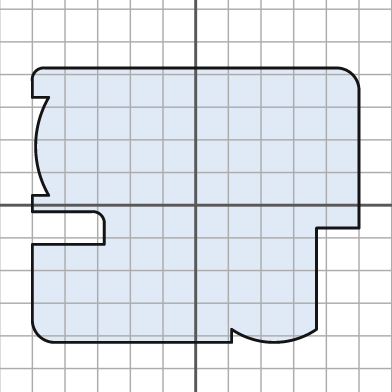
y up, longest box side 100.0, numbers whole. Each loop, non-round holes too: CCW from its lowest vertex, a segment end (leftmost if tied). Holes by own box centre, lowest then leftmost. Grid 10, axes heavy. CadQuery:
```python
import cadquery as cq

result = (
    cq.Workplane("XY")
    .moveTo(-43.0, -42.0)
    .lineTo(11.0, -42.0)
    .lineTo(11.0, -38.0)
    .threePointArc((24.0, -42.0), (37.0, -38.0))
    .lineTo(37.0, -7.0)
    .lineTo(50.0, -7.0)
    .lineTo(50.0, 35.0)
    .threePointArc((48.0, 40.0), (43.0, 42.0))
    .lineTo(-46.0, 42.0)
    .threePointArc((-49.0, 41.0), (-50.0, 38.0))
    .lineTo(-50.0, 33.0)
    .lineTo(-45.0, 33.0)
    .threePointArc((-49.0, 18.0), (-45.0, 3.0))
    .lineTo(-50.0, 3.0)
    .lineTo(-50.0, -2.0)
    .lineTo(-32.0, -2.0)
    .threePointArc((-29.0, -3.0), (-28.0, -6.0))
    .lineTo(-28.0, -12.0)
    .lineTo(-50.0, -12.0)
    .lineTo(-50.0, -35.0)
    .threePointArc((-48.0, -40.0), (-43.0, -42.0))
    .close()
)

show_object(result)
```